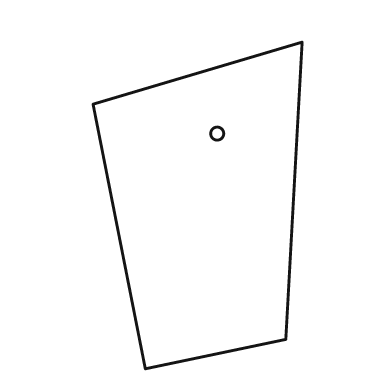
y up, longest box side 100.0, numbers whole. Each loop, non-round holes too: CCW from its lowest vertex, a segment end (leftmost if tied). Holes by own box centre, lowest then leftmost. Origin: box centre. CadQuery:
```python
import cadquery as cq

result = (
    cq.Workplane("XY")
    .moveTo(-16.0, -50.0)
    .lineTo(27.0, -41.0)
    .lineTo(32.0, 50.0)
    .lineTo(-32.0, 31.0)
    .close()
    .moveTo(6.0, 22.0)
    .circle(2.0)
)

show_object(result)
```